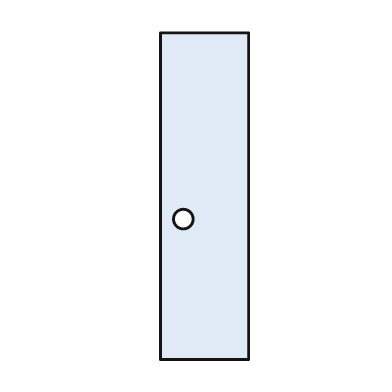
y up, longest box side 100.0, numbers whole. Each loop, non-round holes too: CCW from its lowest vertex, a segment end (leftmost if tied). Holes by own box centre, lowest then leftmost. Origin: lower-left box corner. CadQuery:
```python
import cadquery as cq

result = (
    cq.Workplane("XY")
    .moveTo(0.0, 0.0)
    .lineTo(27.0, 0.0)
    .lineTo(27.0, 100.0)
    .lineTo(0.0, 100.0)
    .close()
    .moveTo(7.0, 43.0)
    .circle(3.0)
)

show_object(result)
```